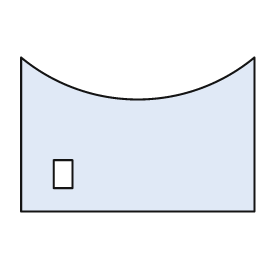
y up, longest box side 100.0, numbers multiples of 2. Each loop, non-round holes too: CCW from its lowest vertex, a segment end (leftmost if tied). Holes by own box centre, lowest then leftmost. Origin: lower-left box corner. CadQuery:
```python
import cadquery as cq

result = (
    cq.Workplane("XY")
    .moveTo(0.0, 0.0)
    .lineTo(100.0, 0.0)
    .lineTo(100.0, 66.0)
    .threePointArc((50.0, 48.0), (0.0, 66.0))
    .close()
    .moveTo(14.0, 10.0)
    .lineTo(22.0, 10.0)
    .lineTo(22.0, 22.0)
    .lineTo(14.0, 22.0)
    .close()
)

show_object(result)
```